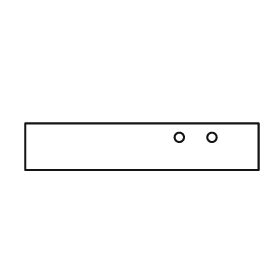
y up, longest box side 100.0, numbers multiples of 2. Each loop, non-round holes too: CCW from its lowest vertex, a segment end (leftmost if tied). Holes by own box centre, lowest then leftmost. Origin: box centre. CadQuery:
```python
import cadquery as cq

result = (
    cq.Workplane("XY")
    .moveTo(-50.0, -10.0)
    .lineTo(50.0, -10.0)
    .lineTo(50.0, 10.0)
    .lineTo(-50.0, 10.0)
    .close()
    .moveTo(16.0, 4.0)
    .circle(2.0)
    .moveTo(30.0, 4.0)
    .circle(2.0)
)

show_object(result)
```